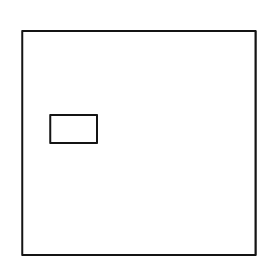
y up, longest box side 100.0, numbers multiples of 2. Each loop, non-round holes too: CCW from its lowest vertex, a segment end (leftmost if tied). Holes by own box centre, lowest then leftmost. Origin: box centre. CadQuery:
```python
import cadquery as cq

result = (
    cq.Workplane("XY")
    .moveTo(-50.0, -48.0)
    .lineTo(50.0, -48.0)
    .lineTo(50.0, 48.0)
    .lineTo(-50.0, 48.0)
    .close()
    .moveTo(-38.0, 0.0)
    .lineTo(-18.0, 0.0)
    .lineTo(-18.0, 12.0)
    .lineTo(-38.0, 12.0)
    .close()
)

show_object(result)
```